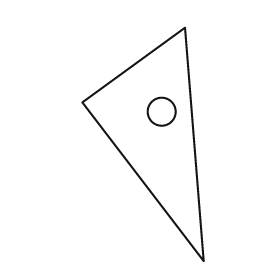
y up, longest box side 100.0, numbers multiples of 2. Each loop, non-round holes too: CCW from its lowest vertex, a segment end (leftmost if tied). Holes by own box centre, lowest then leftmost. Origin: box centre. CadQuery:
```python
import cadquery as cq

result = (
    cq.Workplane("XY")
    .moveTo(26.0, -50.0)
    .lineTo(18.0, 50.0)
    .lineTo(-26.0, 18.0)
    .close()
    .moveTo(8.0, 14.0)
    .circle(6.0)
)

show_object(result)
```